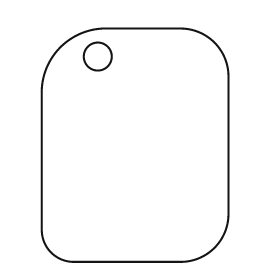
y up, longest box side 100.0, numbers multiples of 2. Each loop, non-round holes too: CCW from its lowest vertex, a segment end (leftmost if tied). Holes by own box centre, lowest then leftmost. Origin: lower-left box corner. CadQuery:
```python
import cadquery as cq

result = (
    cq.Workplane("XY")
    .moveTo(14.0, 0.0)
    .lineTo(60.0, 0.0)
    .threePointArc((74.0, 6.0), (80.0, 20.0))
    .lineTo(80.0, 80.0)
    .threePointArc((74.0, 94.0), (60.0, 100.0))
    .lineTo(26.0, 100.0)
    .threePointArc((8.0, 92.0), (0.0, 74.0))
    .lineTo(0.0, 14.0)
    .threePointArc((4.0, 4.0), (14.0, 0.0))
    .close()
    .moveTo(24.0, 88.0)
    .circle(6.0)
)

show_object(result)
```